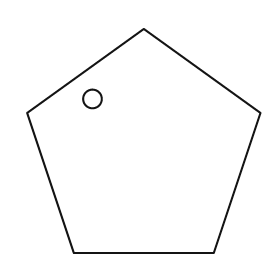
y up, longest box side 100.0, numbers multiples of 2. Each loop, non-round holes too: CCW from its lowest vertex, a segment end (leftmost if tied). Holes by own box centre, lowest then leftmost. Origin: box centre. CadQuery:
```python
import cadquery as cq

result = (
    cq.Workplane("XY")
    .moveTo(-30.0, -48.0)
    .lineTo(30.0, -48.0)
    .lineTo(50.0, 12.0)
    .lineTo(0.0, 48.0)
    .lineTo(-50.0, 12.0)
    .close()
    .moveTo(-22.0, 18.0)
    .circle(4.0)
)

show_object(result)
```